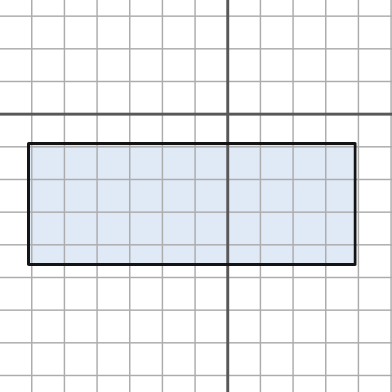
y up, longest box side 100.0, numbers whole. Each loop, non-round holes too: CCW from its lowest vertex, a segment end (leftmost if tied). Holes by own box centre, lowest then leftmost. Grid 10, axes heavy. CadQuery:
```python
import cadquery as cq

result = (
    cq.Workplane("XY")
    .moveTo(-61.0, -46.0)
    .lineTo(39.0, -46.0)
    .lineTo(39.0, -9.0)
    .lineTo(-61.0, -9.0)
    .close()
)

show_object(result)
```